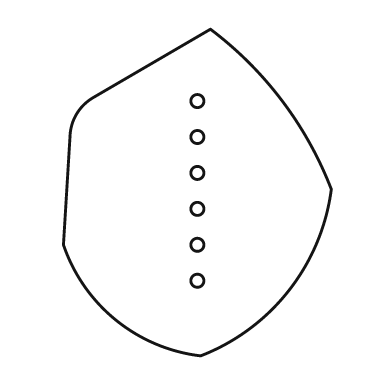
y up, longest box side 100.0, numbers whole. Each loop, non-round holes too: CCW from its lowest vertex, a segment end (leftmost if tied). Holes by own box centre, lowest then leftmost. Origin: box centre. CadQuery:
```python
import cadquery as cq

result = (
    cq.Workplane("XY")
    .moveTo(1.0, -50.0)
    .threePointArc((28.0, -30.0), (41.0, 1.0))
    .threePointArc((26.0, 28.0), (4.0, 50.0))
    .lineTo(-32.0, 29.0)
    .threePointArc((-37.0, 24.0), (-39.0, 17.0))
    .lineTo(-41.0, -16.0)
    .threePointArc((-25.0, -39.0), (1.0, -50.0))
    .close()
    .moveTo(0.0, -27.0)
    .circle(2.0)
    .moveTo(0.0, -16.0)
    .circle(2.0)
    .moveTo(0.0, -5.0)
    .circle(2.0)
    .moveTo(0.0, 6.0)
    .circle(2.0)
    .moveTo(0.0, 17.0)
    .circle(2.0)
    .moveTo(0.0, 28.0)
    .circle(2.0)
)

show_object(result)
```